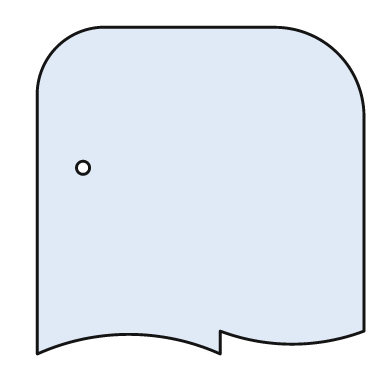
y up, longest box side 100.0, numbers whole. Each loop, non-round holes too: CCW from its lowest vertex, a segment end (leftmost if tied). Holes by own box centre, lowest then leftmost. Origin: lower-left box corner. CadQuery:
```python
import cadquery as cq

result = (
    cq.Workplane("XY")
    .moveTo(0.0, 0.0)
    .threePointArc((28.0, 6.0), (56.0, 0.0))
    .lineTo(56.0, 7.0)
    .threePointArc((78.0, 3.0), (100.0, 7.0))
    .lineTo(100.0, 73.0)
    .threePointArc((92.0, 92.0), (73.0, 100.0))
    .lineTo(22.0, 100.0)
    .threePointArc((6.0, 94.0), (0.0, 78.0))
    .close()
    .moveTo(14.0, 57.0)
    .circle(2.0)
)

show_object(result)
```